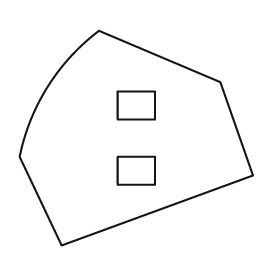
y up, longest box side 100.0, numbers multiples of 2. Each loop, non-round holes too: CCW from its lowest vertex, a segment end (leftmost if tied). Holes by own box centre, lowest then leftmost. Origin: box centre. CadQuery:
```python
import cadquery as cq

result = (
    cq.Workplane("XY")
    .moveTo(-32.0, -46.0)
    .lineTo(50.0, -16.0)
    .lineTo(36.0, 24.0)
    .lineTo(-16.0, 46.0)
    .threePointArc((-38.0, 22.0), (-50.0, -8.0))
    .close()
    .moveTo(-8.0, -20.0)
    .lineTo(8.0, -20.0)
    .lineTo(8.0, -8.0)
    .lineTo(-8.0, -8.0)
    .close()
    .moveTo(-8.0, 8.0)
    .lineTo(8.0, 8.0)
    .lineTo(8.0, 20.0)
    .lineTo(-8.0, 20.0)
    .close()
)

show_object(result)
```